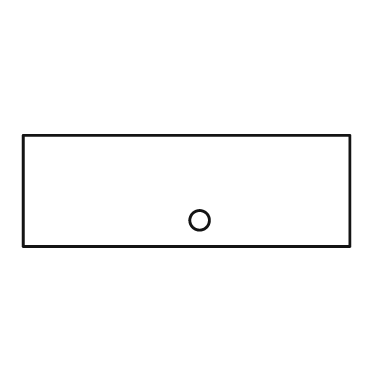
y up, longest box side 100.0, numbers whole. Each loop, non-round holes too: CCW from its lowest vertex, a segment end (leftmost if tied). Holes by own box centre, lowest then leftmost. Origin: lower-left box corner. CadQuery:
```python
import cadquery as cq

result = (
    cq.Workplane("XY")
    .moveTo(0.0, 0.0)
    .lineTo(100.0, 0.0)
    .lineTo(100.0, 34.0)
    .lineTo(0.0, 34.0)
    .close()
    .moveTo(54.0, 8.0)
    .circle(3.0)
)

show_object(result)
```